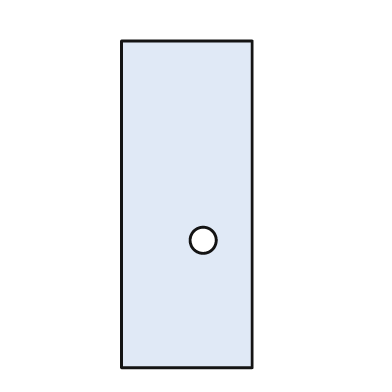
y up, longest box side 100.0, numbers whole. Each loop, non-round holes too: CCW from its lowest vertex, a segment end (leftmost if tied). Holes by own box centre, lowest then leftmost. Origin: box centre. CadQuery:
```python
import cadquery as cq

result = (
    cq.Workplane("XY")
    .moveTo(-20.0, -50.0)
    .lineTo(20.0, -50.0)
    .lineTo(20.0, 50.0)
    .lineTo(-20.0, 50.0)
    .close()
    .moveTo(5.0, -11.0)
    .circle(4.0)
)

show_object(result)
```